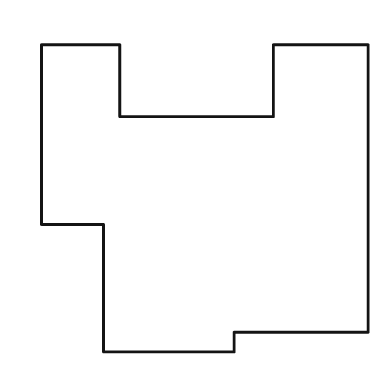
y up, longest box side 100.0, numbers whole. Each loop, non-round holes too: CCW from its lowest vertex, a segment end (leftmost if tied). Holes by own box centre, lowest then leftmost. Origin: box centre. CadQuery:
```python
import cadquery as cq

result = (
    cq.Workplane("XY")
    .moveTo(-31.0, -47.0)
    .lineTo(9.0, -47.0)
    .lineTo(9.0, -41.0)
    .lineTo(50.0, -41.0)
    .lineTo(50.0, 47.0)
    .lineTo(21.0, 47.0)
    .lineTo(21.0, 25.0)
    .lineTo(-26.0, 25.0)
    .lineTo(-26.0, 47.0)
    .lineTo(-50.0, 47.0)
    .lineTo(-50.0, -8.0)
    .lineTo(-31.0, -8.0)
    .close()
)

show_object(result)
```